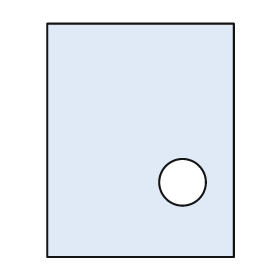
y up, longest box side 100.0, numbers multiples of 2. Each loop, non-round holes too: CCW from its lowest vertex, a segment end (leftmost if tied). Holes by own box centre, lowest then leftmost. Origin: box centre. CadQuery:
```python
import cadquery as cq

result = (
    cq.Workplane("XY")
    .moveTo(-40.0, -50.0)
    .lineTo(40.0, -50.0)
    .lineTo(40.0, 50.0)
    .lineTo(-40.0, 50.0)
    .close()
    .moveTo(18.0, -18.0)
    .circle(10.0)
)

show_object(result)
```